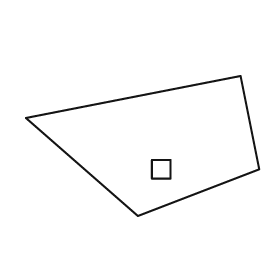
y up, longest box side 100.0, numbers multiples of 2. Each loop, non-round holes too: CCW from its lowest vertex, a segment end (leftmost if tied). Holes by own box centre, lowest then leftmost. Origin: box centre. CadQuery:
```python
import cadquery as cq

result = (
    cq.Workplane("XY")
    .moveTo(-2.0, -30.0)
    .lineTo(50.0, -10.0)
    .lineTo(42.0, 30.0)
    .lineTo(-50.0, 12.0)
    .close()
    .moveTo(4.0, -14.0)
    .lineTo(12.0, -14.0)
    .lineTo(12.0, -6.0)
    .lineTo(4.0, -6.0)
    .close()
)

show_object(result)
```